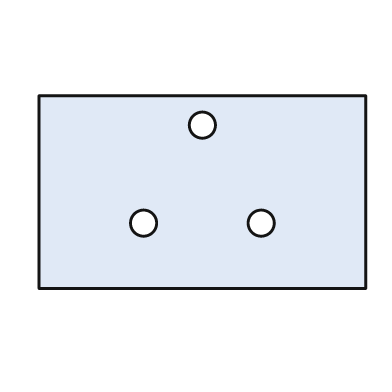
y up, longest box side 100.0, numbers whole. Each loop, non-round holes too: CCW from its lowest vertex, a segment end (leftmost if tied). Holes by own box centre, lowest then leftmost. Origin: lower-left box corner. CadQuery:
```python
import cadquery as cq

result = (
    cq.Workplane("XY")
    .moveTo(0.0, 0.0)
    .lineTo(100.0, 0.0)
    .lineTo(100.0, 59.0)
    .lineTo(0.0, 59.0)
    .close()
    .moveTo(32.0, 20.0)
    .circle(4.0)
    .moveTo(68.0, 20.0)
    .circle(4.0)
    .moveTo(50.0, 50.0)
    .circle(4.0)
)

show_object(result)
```